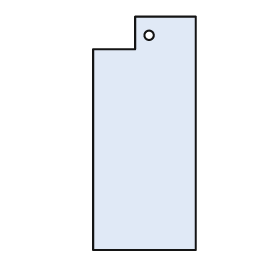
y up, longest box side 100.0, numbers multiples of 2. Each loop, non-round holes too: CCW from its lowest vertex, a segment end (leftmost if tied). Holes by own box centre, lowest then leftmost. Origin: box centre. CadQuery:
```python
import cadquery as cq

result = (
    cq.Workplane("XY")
    .moveTo(-22.0, -50.0)
    .lineTo(22.0, -50.0)
    .lineTo(22.0, 50.0)
    .lineTo(-4.0, 50.0)
    .lineTo(-4.0, 36.0)
    .lineTo(-22.0, 36.0)
    .close()
    .moveTo(2.0, 42.0)
    .circle(2.0)
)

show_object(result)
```